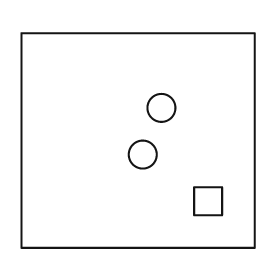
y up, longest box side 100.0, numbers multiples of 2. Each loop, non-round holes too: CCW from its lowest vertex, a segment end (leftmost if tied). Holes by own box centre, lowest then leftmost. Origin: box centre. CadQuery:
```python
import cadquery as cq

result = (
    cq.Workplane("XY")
    .moveTo(-50.0, -46.0)
    .lineTo(50.0, -46.0)
    .lineTo(50.0, 46.0)
    .lineTo(-50.0, 46.0)
    .close()
    .moveTo(24.0, -32.0)
    .lineTo(36.0, -32.0)
    .lineTo(36.0, -20.0)
    .lineTo(24.0, -20.0)
    .close()
    .moveTo(2.0, -6.0)
    .circle(6.0)
    .moveTo(10.0, 14.0)
    .circle(6.0)
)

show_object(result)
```